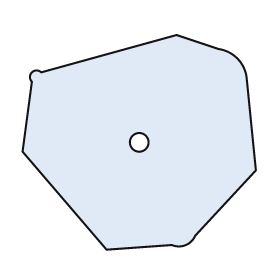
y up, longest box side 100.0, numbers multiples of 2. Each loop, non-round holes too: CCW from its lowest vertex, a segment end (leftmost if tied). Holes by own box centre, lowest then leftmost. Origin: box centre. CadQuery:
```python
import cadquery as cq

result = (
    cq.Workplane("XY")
    .moveTo(-14.0, -46.0)
    .lineTo(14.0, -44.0)
    .threePointArc((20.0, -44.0), (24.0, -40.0))
    .lineTo(50.0, -12.0)
    .lineTo(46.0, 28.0)
    .threePointArc((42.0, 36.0), (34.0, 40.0))
    .lineTo(16.0, 46.0)
    .lineTo(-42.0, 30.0)
    .threePointArc((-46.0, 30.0), (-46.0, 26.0))
    .lineTo(-50.0, -4.0)
    .close()
    .moveTo(0.0, 0.0)
    .circle(4.0)
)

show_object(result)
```